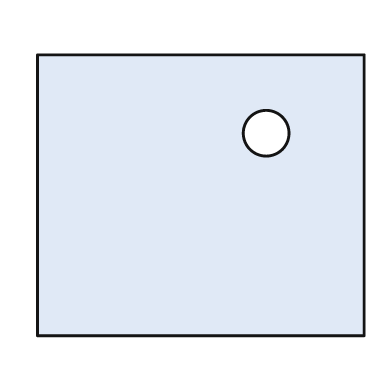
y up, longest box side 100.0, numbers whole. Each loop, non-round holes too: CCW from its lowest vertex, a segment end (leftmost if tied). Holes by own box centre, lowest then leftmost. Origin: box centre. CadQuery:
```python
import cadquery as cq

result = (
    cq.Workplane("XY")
    .moveTo(-50.0, -43.0)
    .lineTo(50.0, -43.0)
    .lineTo(50.0, 43.0)
    .lineTo(-50.0, 43.0)
    .close()
    .moveTo(20.0, 19.0)
    .circle(7.0)
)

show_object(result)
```